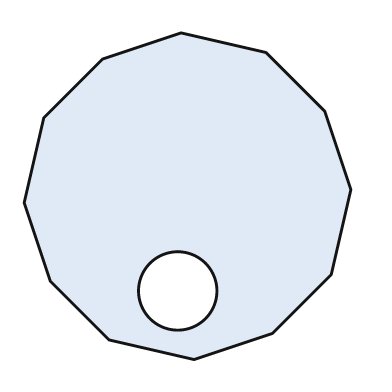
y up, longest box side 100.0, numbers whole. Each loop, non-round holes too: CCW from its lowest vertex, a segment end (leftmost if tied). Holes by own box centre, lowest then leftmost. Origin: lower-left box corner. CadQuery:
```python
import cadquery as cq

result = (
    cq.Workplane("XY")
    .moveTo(52.0, 0.0)
    .lineTo(76.0, 8.0)
    .lineTo(94.0, 26.0)
    .lineTo(100.0, 52.0)
    .lineTo(92.0, 76.0)
    .lineTo(74.0, 94.0)
    .lineTo(48.0, 100.0)
    .lineTo(24.0, 92.0)
    .lineTo(6.0, 74.0)
    .lineTo(0.0, 48.0)
    .lineTo(8.0, 24.0)
    .lineTo(26.0, 6.0)
    .close()
    .moveTo(47.0, 21.0)
    .circle(12.0)
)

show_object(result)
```